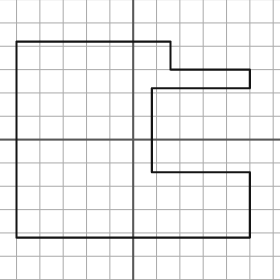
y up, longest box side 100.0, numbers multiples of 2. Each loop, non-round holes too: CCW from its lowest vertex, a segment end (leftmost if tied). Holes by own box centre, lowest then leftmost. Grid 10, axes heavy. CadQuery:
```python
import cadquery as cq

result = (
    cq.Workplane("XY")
    .moveTo(-50.0, -42.0)
    .lineTo(50.0, -42.0)
    .lineTo(50.0, -14.0)
    .lineTo(8.0, -14.0)
    .lineTo(8.0, 22.0)
    .lineTo(50.0, 22.0)
    .lineTo(50.0, 30.0)
    .lineTo(16.0, 30.0)
    .lineTo(16.0, 42.0)
    .lineTo(-50.0, 42.0)
    .close()
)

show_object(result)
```